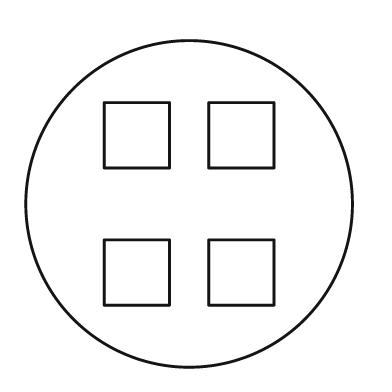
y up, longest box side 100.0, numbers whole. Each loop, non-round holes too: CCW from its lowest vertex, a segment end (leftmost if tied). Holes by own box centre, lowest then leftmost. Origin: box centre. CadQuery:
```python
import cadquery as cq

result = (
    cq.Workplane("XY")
    .moveTo(0.0, 0.0)
    .circle(50.0)
    .moveTo(-26.0, -31.0)
    .lineTo(-6.0, -31.0)
    .lineTo(-6.0, -11.0)
    .lineTo(-26.0, -11.0)
    .close()
    .moveTo(6.0, -31.0)
    .lineTo(26.0, -31.0)
    .lineTo(26.0, -11.0)
    .lineTo(6.0, -11.0)
    .close()
    .moveTo(-26.0, 11.0)
    .lineTo(-6.0, 11.0)
    .lineTo(-6.0, 31.0)
    .lineTo(-26.0, 31.0)
    .close()
    .moveTo(6.0, 11.0)
    .lineTo(26.0, 11.0)
    .lineTo(26.0, 31.0)
    .lineTo(6.0, 31.0)
    .close()
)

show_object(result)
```